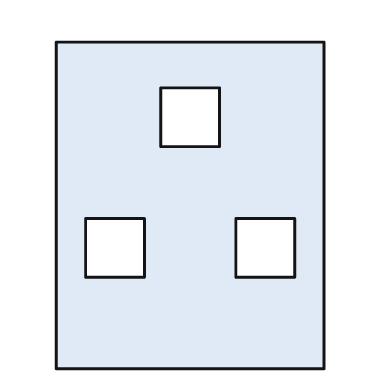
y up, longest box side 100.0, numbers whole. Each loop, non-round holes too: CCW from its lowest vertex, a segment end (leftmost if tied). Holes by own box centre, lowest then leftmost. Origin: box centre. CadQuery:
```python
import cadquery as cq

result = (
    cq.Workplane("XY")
    .moveTo(-41.0, -50.0)
    .lineTo(41.0, -50.0)
    .lineTo(41.0, 50.0)
    .lineTo(-41.0, 50.0)
    .close()
    .moveTo(-32.0, -22.0)
    .lineTo(-14.0, -22.0)
    .lineTo(-14.0, -4.0)
    .lineTo(-32.0, -4.0)
    .close()
    .moveTo(14.0, -22.0)
    .lineTo(32.0, -22.0)
    .lineTo(32.0, -4.0)
    .lineTo(14.0, -4.0)
    .close()
    .moveTo(-9.0, 18.0)
    .lineTo(9.0, 18.0)
    .lineTo(9.0, 36.0)
    .lineTo(-9.0, 36.0)
    .close()
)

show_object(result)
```